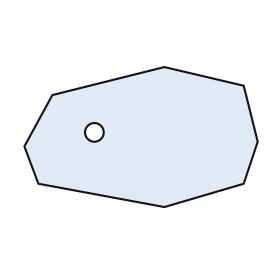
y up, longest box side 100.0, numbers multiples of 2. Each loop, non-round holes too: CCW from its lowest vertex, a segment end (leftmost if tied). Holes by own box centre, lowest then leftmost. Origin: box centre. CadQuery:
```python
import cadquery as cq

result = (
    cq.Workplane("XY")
    .moveTo(10.0, -30.0)
    .lineTo(44.0, -20.0)
    .lineTo(50.0, -2.0)
    .lineTo(44.0, 22.0)
    .lineTo(10.0, 30.0)
    .lineTo(-38.0, 18.0)
    .lineTo(-50.0, -4.0)
    .lineTo(-44.0, -20.0)
    .close()
    .moveTo(-20.0, 2.0)
    .circle(4.0)
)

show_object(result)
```